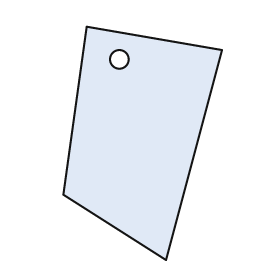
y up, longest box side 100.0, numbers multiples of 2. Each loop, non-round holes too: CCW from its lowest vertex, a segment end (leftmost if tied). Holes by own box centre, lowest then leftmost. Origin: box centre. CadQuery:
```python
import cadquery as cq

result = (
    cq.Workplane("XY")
    .moveTo(10.0, -50.0)
    .lineTo(34.0, 40.0)
    .lineTo(-24.0, 50.0)
    .lineTo(-34.0, -22.0)
    .close()
    .moveTo(-10.0, 36.0)
    .circle(4.0)
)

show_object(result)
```